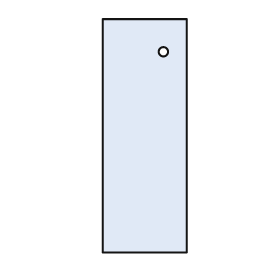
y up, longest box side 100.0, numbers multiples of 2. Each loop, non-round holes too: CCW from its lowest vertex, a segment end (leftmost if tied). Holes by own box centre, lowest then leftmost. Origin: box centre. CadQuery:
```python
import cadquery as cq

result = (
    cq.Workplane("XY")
    .moveTo(-18.0, -50.0)
    .lineTo(18.0, -50.0)
    .lineTo(18.0, 50.0)
    .lineTo(-18.0, 50.0)
    .close()
    .moveTo(8.0, 36.0)
    .circle(2.0)
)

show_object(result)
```